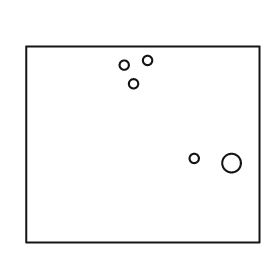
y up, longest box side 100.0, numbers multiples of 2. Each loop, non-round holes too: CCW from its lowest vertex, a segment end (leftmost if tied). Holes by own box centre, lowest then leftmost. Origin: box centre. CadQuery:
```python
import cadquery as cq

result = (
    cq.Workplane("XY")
    .moveTo(-50.0, -42.0)
    .lineTo(50.0, -42.0)
    .lineTo(50.0, 42.0)
    .lineTo(-50.0, 42.0)
    .close()
    .moveTo(38.0, -8.0)
    .circle(4.0)
    .moveTo(22.0, -6.0)
    .circle(2.0)
    .moveTo(-4.0, 26.0)
    .circle(2.0)
    .moveTo(-8.0, 34.0)
    .circle(2.0)
    .moveTo(2.0, 36.0)
    .circle(2.0)
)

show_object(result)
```